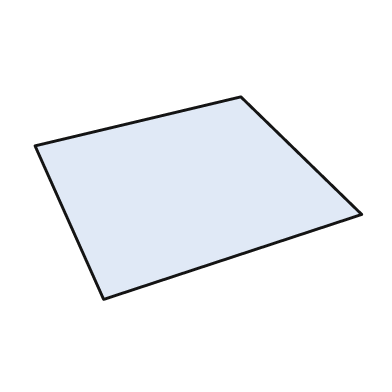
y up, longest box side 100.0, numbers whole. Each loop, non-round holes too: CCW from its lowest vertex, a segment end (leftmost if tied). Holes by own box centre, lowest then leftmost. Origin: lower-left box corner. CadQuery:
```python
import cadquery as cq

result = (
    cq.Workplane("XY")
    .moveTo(21.0, 0.0)
    .lineTo(100.0, 26.0)
    .lineTo(63.0, 62.0)
    .lineTo(0.0, 47.0)
    .close()
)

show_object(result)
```